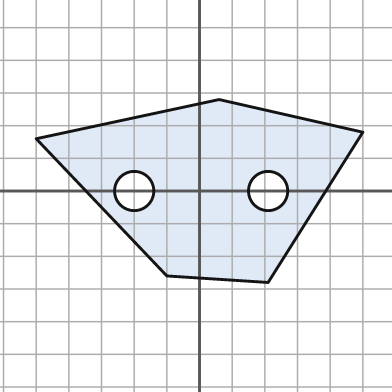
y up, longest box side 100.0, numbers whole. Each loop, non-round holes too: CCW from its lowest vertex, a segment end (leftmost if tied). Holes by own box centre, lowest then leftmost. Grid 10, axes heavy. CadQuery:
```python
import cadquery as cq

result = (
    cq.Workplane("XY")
    .moveTo(21.0, -28.0)
    .lineTo(50.0, 18.0)
    .lineTo(6.0, 28.0)
    .lineTo(-50.0, 16.0)
    .lineTo(-10.0, -26.0)
    .close()
    .moveTo(-20.0, 0.0)
    .circle(6.0)
    .moveTo(21.0, 0.0)
    .circle(6.0)
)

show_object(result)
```